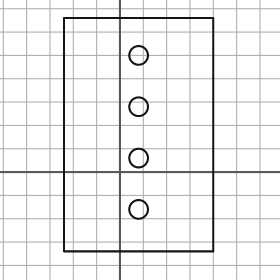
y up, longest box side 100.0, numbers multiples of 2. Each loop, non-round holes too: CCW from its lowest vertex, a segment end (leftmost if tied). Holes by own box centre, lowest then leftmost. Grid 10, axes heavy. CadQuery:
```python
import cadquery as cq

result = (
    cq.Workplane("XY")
    .moveTo(-24.0, -34.0)
    .lineTo(40.0, -34.0)
    .lineTo(40.0, 66.0)
    .lineTo(-24.0, 66.0)
    .close()
    .moveTo(8.0, -16.0)
    .circle(4.0)
    .moveTo(8.0, 6.0)
    .circle(4.0)
    .moveTo(8.0, 28.0)
    .circle(4.0)
    .moveTo(8.0, 50.0)
    .circle(4.0)
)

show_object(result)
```